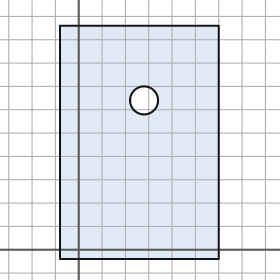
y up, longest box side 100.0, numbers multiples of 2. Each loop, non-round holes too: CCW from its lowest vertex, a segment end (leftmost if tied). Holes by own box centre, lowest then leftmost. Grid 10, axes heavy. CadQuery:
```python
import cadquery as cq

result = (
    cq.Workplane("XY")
    .moveTo(-8.0, -4.0)
    .lineTo(60.0, -4.0)
    .lineTo(60.0, 96.0)
    .lineTo(-8.0, 96.0)
    .close()
    .moveTo(28.0, 64.0)
    .circle(6.0)
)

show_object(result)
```